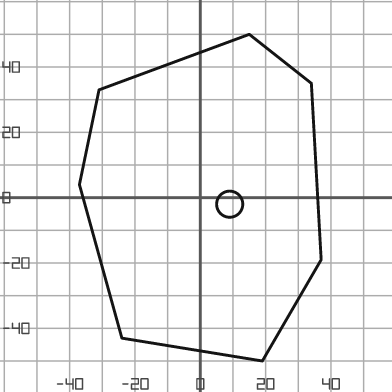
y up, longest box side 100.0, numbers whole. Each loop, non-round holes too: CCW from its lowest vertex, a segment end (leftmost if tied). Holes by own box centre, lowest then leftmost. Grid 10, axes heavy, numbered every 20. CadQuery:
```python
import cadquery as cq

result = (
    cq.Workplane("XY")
    .moveTo(19.0, -50.0)
    .lineTo(37.0, -19.0)
    .lineTo(34.0, 35.0)
    .lineTo(15.0, 50.0)
    .lineTo(-31.0, 33.0)
    .lineTo(-37.0, 4.0)
    .lineTo(-24.0, -43.0)
    .close()
    .moveTo(9.0, -2.0)
    .circle(4.0)
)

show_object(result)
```